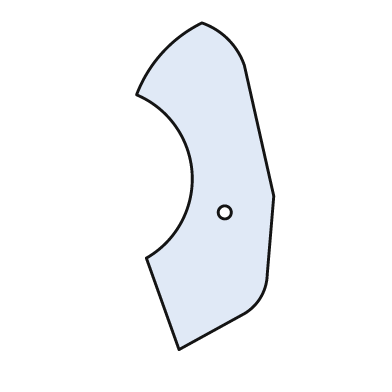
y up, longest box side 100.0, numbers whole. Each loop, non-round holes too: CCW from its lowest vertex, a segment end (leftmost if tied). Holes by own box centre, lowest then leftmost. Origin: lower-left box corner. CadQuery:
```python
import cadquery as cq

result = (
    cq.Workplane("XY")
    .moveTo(13.0, 0.0)
    .lineTo(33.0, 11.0)
    .threePointArc((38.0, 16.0), (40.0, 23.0))
    .lineTo(42.0, 47.0)
    .lineTo(33.0, 87.0)
    .threePointArc((28.0, 95.0), (20.0, 100.0))
    .threePointArc((8.0, 91.0), (0.0, 78.0))
    .threePointArc((17.0, 54.0), (3.0, 28.0))
    .close()
    .moveTo(27.0, 42.0)
    .circle(2.0)
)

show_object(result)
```